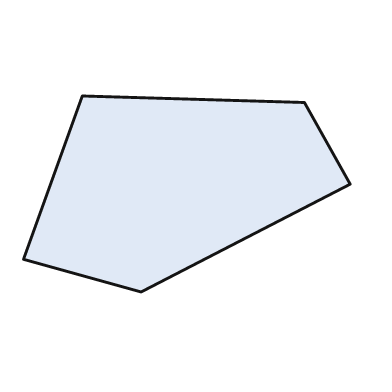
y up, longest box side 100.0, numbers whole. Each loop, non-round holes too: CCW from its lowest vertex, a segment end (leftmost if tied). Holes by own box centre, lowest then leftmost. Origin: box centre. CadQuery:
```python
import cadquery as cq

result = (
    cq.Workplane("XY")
    .moveTo(-14.0, -30.0)
    .lineTo(50.0, 3.0)
    .lineTo(36.0, 28.0)
    .lineTo(-32.0, 30.0)
    .lineTo(-50.0, -20.0)
    .close()
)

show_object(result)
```